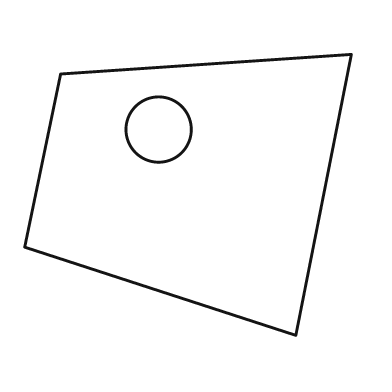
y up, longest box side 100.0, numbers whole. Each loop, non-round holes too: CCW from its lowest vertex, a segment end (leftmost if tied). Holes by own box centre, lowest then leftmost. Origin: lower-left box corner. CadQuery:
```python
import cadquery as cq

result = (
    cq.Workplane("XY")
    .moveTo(83.0, 0.0)
    .lineTo(100.0, 86.0)
    .lineTo(11.0, 80.0)
    .lineTo(0.0, 27.0)
    .close()
    .moveTo(41.0, 63.0)
    .circle(10.0)
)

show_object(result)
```